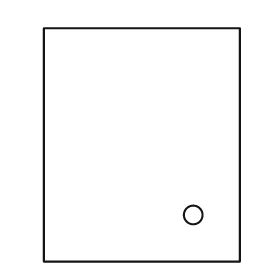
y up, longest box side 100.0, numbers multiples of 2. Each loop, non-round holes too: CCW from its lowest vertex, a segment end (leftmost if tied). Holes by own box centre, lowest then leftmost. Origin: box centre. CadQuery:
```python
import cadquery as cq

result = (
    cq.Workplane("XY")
    .moveTo(-42.0, -50.0)
    .lineTo(42.0, -50.0)
    .lineTo(42.0, 50.0)
    .lineTo(-42.0, 50.0)
    .close()
    .moveTo(22.0, -30.0)
    .circle(4.0)
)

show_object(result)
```